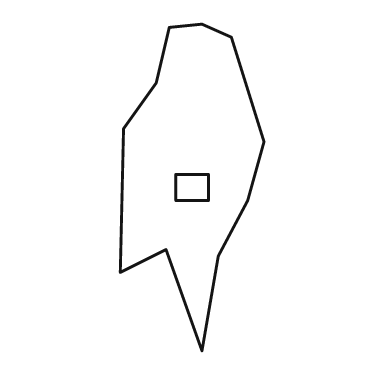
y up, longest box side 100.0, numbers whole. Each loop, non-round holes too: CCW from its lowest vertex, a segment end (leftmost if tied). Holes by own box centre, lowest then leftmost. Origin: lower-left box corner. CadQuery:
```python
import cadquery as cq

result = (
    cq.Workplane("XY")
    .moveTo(25.0, 0.0)
    .lineTo(30.0, 29.0)
    .lineTo(39.0, 46.0)
    .lineTo(44.0, 64.0)
    .lineTo(34.0, 96.0)
    .lineTo(25.0, 100.0)
    .lineTo(15.0, 99.0)
    .lineTo(11.0, 82.0)
    .lineTo(1.0, 68.0)
    .lineTo(0.0, 24.0)
    .lineTo(14.0, 31.0)
    .close()
    .moveTo(17.0, 46.0)
    .lineTo(27.0, 46.0)
    .lineTo(27.0, 54.0)
    .lineTo(17.0, 54.0)
    .close()
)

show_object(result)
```